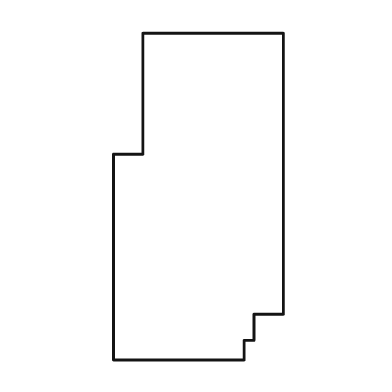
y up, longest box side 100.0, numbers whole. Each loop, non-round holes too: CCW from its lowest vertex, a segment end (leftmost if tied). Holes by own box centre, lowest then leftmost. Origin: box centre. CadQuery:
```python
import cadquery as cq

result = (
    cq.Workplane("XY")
    .moveTo(-26.0, -50.0)
    .lineTo(14.0, -50.0)
    .lineTo(14.0, -44.0)
    .lineTo(17.0, -44.0)
    .lineTo(17.0, -36.0)
    .lineTo(26.0, -36.0)
    .lineTo(26.0, 50.0)
    .lineTo(-17.0, 50.0)
    .lineTo(-17.0, 13.0)
    .lineTo(-26.0, 13.0)
    .close()
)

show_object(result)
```